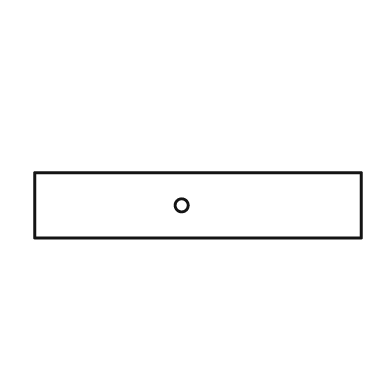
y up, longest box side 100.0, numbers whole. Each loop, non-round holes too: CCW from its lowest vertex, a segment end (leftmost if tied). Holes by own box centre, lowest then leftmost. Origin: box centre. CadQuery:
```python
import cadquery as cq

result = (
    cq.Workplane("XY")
    .moveTo(-50.0, -10.0)
    .lineTo(50.0, -10.0)
    .lineTo(50.0, 10.0)
    .lineTo(-50.0, 10.0)
    .close()
    .moveTo(-5.0, 0.0)
    .circle(2.0)
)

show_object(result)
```